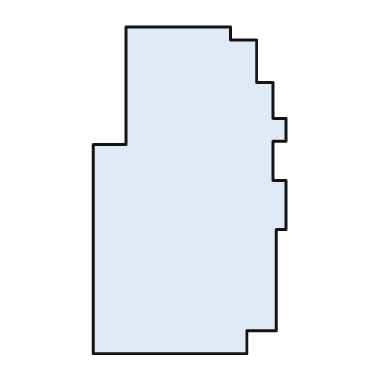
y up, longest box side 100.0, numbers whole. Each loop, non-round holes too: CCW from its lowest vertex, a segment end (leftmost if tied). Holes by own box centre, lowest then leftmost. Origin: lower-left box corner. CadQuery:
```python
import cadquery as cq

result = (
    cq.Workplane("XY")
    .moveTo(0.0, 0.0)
    .lineTo(47.0, 0.0)
    .lineTo(47.0, 7.0)
    .lineTo(56.0, 7.0)
    .lineTo(56.0, 38.0)
    .lineTo(59.0, 38.0)
    .lineTo(59.0, 53.0)
    .lineTo(55.0, 53.0)
    .lineTo(55.0, 65.0)
    .lineTo(59.0, 65.0)
    .lineTo(59.0, 72.0)
    .lineTo(55.0, 72.0)
    .lineTo(55.0, 83.0)
    .lineTo(50.0, 83.0)
    .lineTo(50.0, 96.0)
    .lineTo(42.0, 96.0)
    .lineTo(42.0, 100.0)
    .lineTo(10.0, 100.0)
    .lineTo(10.0, 64.0)
    .lineTo(0.0, 64.0)
    .close()
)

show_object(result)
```